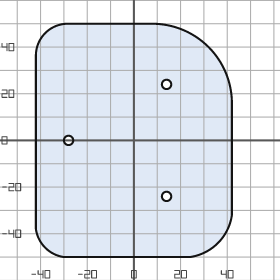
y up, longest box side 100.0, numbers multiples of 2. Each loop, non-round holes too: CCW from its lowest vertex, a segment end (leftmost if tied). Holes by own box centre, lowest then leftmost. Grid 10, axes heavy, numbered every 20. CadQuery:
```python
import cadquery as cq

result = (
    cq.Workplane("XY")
    .moveTo(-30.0, -50.0)
    .lineTo(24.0, -50.0)
    .threePointArc((36.0, -44.0), (42.0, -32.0))
    .lineTo(42.0, 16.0)
    .threePointArc((32.0, 40.0), (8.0, 50.0))
    .lineTo(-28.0, 50.0)
    .threePointArc((-38.0, 46.0), (-42.0, 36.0))
    .lineTo(-42.0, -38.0)
    .threePointArc((-38.0, -46.0), (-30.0, -50.0))
    .close()
    .moveTo(14.0, -24.0)
    .circle(2.0)
    .moveTo(-28.0, 0.0)
    .circle(2.0)
    .moveTo(14.0, 24.0)
    .circle(2.0)
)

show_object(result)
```